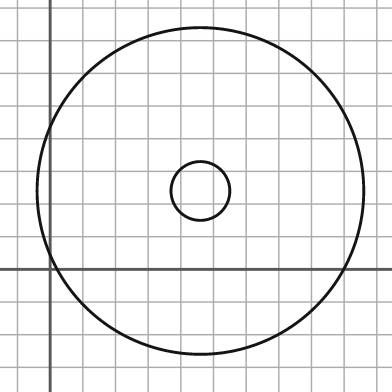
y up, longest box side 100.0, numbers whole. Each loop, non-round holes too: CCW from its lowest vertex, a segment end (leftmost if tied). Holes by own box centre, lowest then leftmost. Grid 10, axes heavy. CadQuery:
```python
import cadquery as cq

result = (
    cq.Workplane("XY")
    .moveTo(46.0, 24.0)
    .circle(50.0)
    .moveTo(46.0, 24.0)
    .circle(9.0)
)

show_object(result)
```